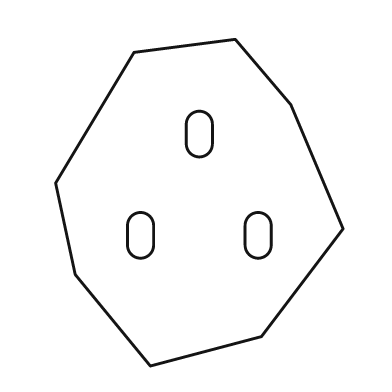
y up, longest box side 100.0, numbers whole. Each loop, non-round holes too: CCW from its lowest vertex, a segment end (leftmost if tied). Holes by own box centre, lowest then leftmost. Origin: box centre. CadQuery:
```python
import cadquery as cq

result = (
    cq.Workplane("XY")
    .moveTo(-15.0, -50.0)
    .lineTo(19.0, -41.0)
    .lineTo(44.0, -8.0)
    .lineTo(28.0, 30.0)
    .lineTo(11.0, 50.0)
    .lineTo(-20.0, 46.0)
    .lineTo(-44.0, 6.0)
    .lineTo(-38.0, -22.0)
    .close()
    .moveTo(-22.0, -13.0)
    .threePointArc((-18.0, -17.0), (-14.0, -13.0))
    .lineTo(-14.0, -7.0)
    .threePointArc((-18.0, -3.0), (-22.0, -7.0))
    .close()
    .moveTo(14.0, -13.0)
    .threePointArc((18.0, -17.0), (22.0, -13.0))
    .lineTo(22.0, -7.0)
    .threePointArc((18.0, -3.0), (14.0, -7.0))
    .close()
    .moveTo(-4.0, 18.0)
    .threePointArc((0.0, 14.0), (4.0, 18.0))
    .lineTo(4.0, 24.0)
    .threePointArc((0.0, 28.0), (-4.0, 24.0))
    .close()
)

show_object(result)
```